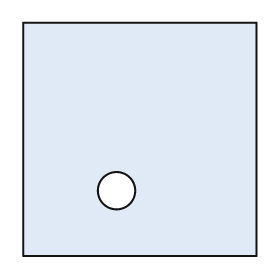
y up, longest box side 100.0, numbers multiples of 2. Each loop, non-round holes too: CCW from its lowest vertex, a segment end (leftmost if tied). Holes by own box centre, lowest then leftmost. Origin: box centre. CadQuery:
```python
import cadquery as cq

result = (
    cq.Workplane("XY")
    .moveTo(-50.0, -50.0)
    .lineTo(50.0, -50.0)
    .lineTo(50.0, 50.0)
    .lineTo(-50.0, 50.0)
    .close()
    .moveTo(-10.0, -22.0)
    .circle(8.0)
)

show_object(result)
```